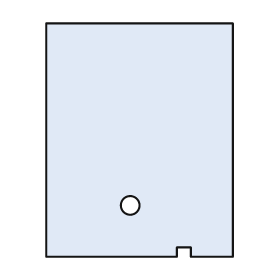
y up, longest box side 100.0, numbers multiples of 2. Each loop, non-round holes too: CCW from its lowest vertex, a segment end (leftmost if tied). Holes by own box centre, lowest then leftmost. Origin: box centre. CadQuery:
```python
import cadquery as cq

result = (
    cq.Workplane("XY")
    .moveTo(-40.0, -50.0)
    .lineTo(16.0, -50.0)
    .lineTo(16.0, -46.0)
    .lineTo(22.0, -46.0)
    .lineTo(22.0, -50.0)
    .lineTo(40.0, -50.0)
    .lineTo(40.0, 50.0)
    .lineTo(-40.0, 50.0)
    .close()
    .moveTo(-4.0, -28.0)
    .circle(4.0)
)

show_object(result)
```